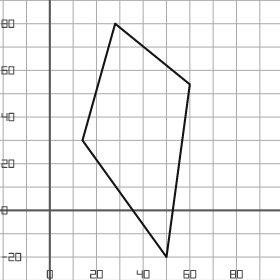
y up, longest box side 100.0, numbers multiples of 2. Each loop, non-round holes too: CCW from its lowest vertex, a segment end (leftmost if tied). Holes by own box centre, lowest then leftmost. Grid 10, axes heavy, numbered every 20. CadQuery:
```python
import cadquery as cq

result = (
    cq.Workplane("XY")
    .moveTo(50.0, -20.0)
    .lineTo(60.0, 54.0)
    .lineTo(28.0, 80.0)
    .lineTo(14.0, 30.0)
    .close()
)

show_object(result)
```